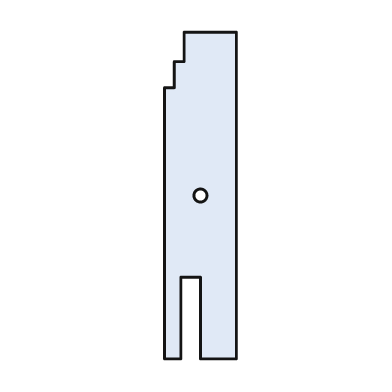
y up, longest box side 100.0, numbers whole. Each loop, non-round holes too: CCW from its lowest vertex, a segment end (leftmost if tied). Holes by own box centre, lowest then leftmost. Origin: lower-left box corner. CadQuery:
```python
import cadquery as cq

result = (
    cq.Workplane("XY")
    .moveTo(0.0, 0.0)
    .lineTo(5.0, 0.0)
    .lineTo(5.0, 25.0)
    .lineTo(11.0, 25.0)
    .lineTo(11.0, 0.0)
    .lineTo(22.0, 0.0)
    .lineTo(22.0, 100.0)
    .lineTo(6.0, 100.0)
    .lineTo(6.0, 91.0)
    .lineTo(3.0, 91.0)
    .lineTo(3.0, 83.0)
    .lineTo(0.0, 83.0)
    .close()
    .moveTo(11.0, 50.0)
    .circle(2.0)
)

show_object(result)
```